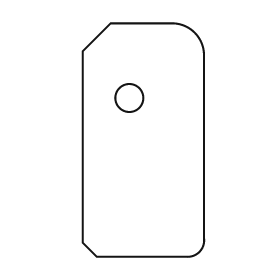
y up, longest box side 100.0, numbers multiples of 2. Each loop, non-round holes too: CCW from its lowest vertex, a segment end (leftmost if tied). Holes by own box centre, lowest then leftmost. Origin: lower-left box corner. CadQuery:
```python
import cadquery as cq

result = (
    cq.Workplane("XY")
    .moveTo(6.0, 0.0)
    .lineTo(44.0, 0.0)
    .threePointArc((50.0, 2.0), (52.0, 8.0))
    .lineTo(52.0, 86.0)
    .threePointArc((48.0, 96.0), (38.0, 100.0))
    .lineTo(12.0, 100.0)
    .lineTo(0.0, 88.0)
    .lineTo(0.0, 6.0)
    .close()
    .moveTo(20.0, 68.0)
    .circle(6.0)
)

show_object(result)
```